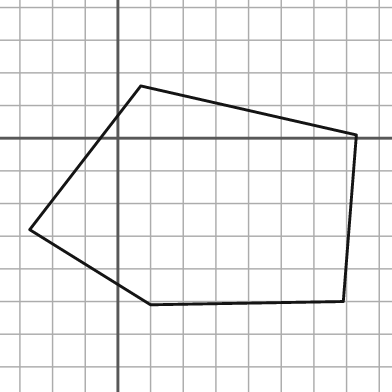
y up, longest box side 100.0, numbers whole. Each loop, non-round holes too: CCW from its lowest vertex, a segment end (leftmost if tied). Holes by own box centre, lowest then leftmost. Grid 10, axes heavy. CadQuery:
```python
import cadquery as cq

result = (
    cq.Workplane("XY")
    .moveTo(10.0, -51.0)
    .lineTo(69.0, -50.0)
    .lineTo(73.0, 1.0)
    .lineTo(7.0, 16.0)
    .lineTo(-27.0, -28.0)
    .close()
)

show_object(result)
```